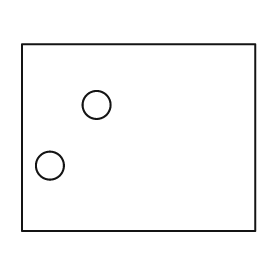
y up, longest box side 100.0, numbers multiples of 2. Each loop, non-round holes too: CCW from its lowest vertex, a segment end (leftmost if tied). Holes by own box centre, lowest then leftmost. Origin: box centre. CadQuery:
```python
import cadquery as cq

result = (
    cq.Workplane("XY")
    .moveTo(-50.0, -40.0)
    .lineTo(50.0, -40.0)
    .lineTo(50.0, 40.0)
    .lineTo(-50.0, 40.0)
    .close()
    .moveTo(-38.0, -12.0)
    .circle(6.0)
    .moveTo(-18.0, 14.0)
    .circle(6.0)
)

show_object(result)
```